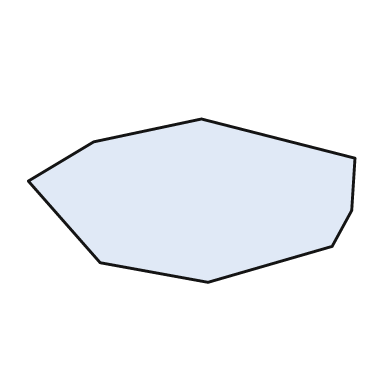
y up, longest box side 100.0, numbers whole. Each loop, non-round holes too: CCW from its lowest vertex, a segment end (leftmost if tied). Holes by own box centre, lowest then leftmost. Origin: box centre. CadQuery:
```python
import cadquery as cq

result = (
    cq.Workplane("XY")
    .moveTo(5.0, -25.0)
    .lineTo(43.0, -14.0)
    .lineTo(49.0, -3.0)
    .lineTo(50.0, 13.0)
    .lineTo(3.0, 25.0)
    .lineTo(-30.0, 18.0)
    .lineTo(-50.0, 6.0)
    .lineTo(-28.0, -19.0)
    .close()
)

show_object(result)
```